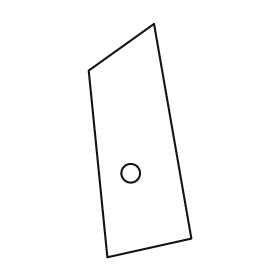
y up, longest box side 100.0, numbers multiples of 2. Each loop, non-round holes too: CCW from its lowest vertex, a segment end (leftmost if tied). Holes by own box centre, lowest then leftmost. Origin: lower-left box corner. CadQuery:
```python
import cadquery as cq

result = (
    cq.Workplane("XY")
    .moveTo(8.0, 0.0)
    .lineTo(44.0, 8.0)
    .lineTo(28.0, 100.0)
    .lineTo(0.0, 80.0)
    .close()
    .moveTo(18.0, 36.0)
    .circle(4.0)
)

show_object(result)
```